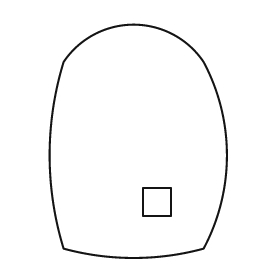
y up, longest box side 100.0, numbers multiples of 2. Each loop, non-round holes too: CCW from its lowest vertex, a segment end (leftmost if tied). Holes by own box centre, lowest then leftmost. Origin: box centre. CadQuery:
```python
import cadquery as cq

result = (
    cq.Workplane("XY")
    .moveTo(-32.0, -46.0)
    .threePointArc((-2.0, -50.0), (28.0, -46.0))
    .threePointArc((38.0, -6.0), (28.0, 34.0))
    .threePointArc((-2.0, 50.0), (-32.0, 34.0))
    .threePointArc((-38.0, -6.0), (-32.0, -46.0))
    .close()
    .moveTo(2.0, -32.0)
    .lineTo(14.0, -32.0)
    .lineTo(14.0, -20.0)
    .lineTo(2.0, -20.0)
    .close()
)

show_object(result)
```